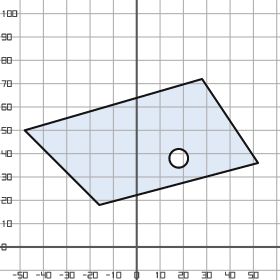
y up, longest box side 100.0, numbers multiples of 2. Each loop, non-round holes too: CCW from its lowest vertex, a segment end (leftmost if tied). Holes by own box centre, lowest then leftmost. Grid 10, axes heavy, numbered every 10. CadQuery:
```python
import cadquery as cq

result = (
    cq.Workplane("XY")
    .moveTo(-16.0, 18.0)
    .lineTo(52.0, 36.0)
    .lineTo(28.0, 72.0)
    .lineTo(-48.0, 50.0)
    .close()
    .moveTo(18.0, 38.0)
    .circle(4.0)
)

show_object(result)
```